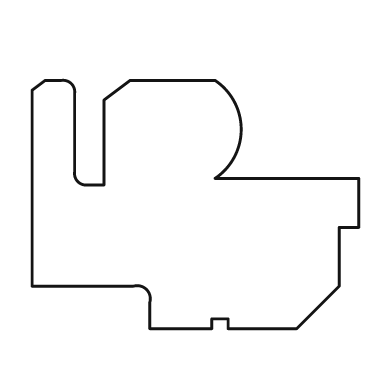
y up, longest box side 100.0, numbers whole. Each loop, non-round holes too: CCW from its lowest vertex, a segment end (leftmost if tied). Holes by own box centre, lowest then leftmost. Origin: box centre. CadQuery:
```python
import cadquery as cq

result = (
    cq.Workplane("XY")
    .moveTo(-14.0, -38.0)
    .lineTo(5.0, -38.0)
    .lineTo(5.0, -35.0)
    .lineTo(10.0, -35.0)
    .lineTo(10.0, -38.0)
    .lineTo(31.0, -38.0)
    .lineTo(44.0, -25.0)
    .lineTo(44.0, -7.0)
    .lineTo(50.0, -7.0)
    .lineTo(50.0, 8.0)
    .lineTo(6.0, 8.0)
    .threePointArc((14.0, 23.0), (6.0, 38.0))
    .lineTo(-20.0, 38.0)
    .lineTo(-28.0, 32.0)
    .lineTo(-28.0, 6.0)
    .lineTo(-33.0, 6.0)
    .threePointArc((-36.0, 7.0), (-37.0, 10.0))
    .lineTo(-37.0, 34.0)
    .threePointArc((-38.0, 37.0), (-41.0, 38.0))
    .lineTo(-46.0, 38.0)
    .lineTo(-50.0, 35.0)
    .lineTo(-50.0, -25.0)
    .lineTo(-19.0, -25.0)
    .threePointArc((-15.0, -26.0), (-14.0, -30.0))
    .close()
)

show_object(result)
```